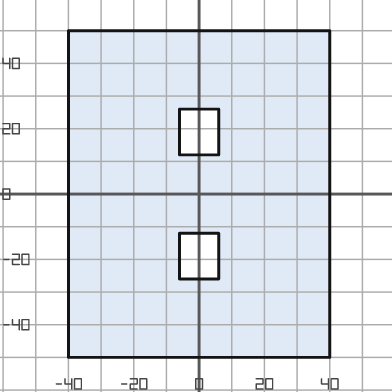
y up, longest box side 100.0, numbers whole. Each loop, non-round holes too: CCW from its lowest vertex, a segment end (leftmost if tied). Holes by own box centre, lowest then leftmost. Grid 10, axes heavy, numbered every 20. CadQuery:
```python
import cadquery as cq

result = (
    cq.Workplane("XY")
    .moveTo(-40.0, -50.0)
    .lineTo(40.0, -50.0)
    .lineTo(40.0, 50.0)
    .lineTo(-40.0, 50.0)
    .close()
    .moveTo(-6.0, -26.0)
    .lineTo(6.0, -26.0)
    .lineTo(6.0, -12.0)
    .lineTo(-6.0, -12.0)
    .close()
    .moveTo(-6.0, 12.0)
    .lineTo(6.0, 12.0)
    .lineTo(6.0, 26.0)
    .lineTo(-6.0, 26.0)
    .close()
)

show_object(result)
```